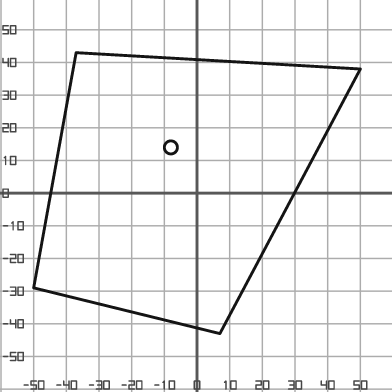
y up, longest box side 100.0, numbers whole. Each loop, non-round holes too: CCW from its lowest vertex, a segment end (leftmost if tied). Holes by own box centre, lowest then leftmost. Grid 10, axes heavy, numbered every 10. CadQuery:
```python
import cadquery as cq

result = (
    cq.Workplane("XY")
    .moveTo(7.0, -43.0)
    .lineTo(50.0, 38.0)
    .lineTo(-37.0, 43.0)
    .lineTo(-50.0, -29.0)
    .close()
    .moveTo(-8.0, 14.0)
    .circle(2.0)
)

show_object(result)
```